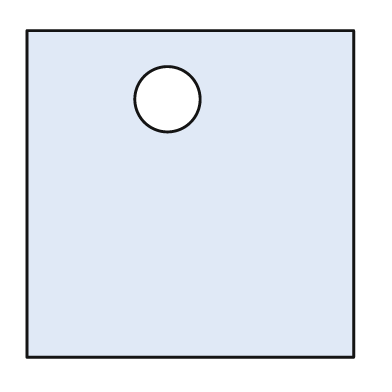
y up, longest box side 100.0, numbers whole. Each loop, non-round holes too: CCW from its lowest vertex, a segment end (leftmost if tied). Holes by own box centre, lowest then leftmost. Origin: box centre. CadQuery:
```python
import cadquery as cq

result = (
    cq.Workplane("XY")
    .moveTo(-50.0, -50.0)
    .lineTo(50.0, -50.0)
    .lineTo(50.0, 50.0)
    .lineTo(-50.0, 50.0)
    .close()
    .moveTo(-7.0, 29.0)
    .circle(10.0)
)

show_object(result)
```